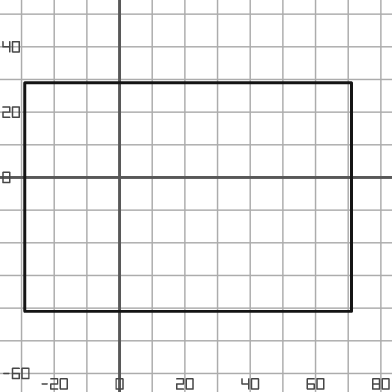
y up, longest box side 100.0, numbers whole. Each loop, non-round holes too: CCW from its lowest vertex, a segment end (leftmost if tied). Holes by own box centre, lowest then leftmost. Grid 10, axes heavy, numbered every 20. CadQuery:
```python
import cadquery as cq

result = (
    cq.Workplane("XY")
    .moveTo(-29.0, -41.0)
    .lineTo(71.0, -41.0)
    .lineTo(71.0, 29.0)
    .lineTo(-29.0, 29.0)
    .close()
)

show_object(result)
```